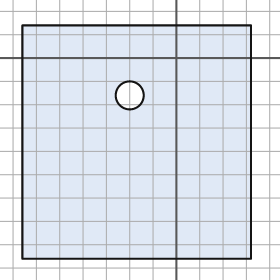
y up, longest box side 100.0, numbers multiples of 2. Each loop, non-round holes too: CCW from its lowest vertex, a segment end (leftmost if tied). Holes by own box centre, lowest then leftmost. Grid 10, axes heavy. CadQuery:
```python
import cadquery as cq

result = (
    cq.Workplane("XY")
    .moveTo(-66.0, -86.0)
    .lineTo(32.0, -86.0)
    .lineTo(32.0, 14.0)
    .lineTo(-66.0, 14.0)
    .close()
    .moveTo(-20.0, -16.0)
    .circle(6.0)
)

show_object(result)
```